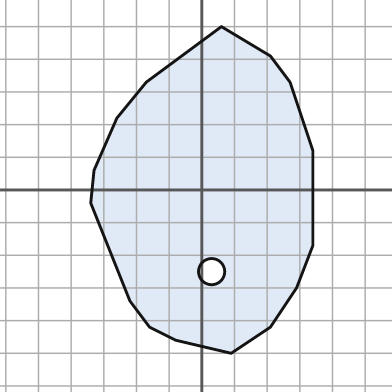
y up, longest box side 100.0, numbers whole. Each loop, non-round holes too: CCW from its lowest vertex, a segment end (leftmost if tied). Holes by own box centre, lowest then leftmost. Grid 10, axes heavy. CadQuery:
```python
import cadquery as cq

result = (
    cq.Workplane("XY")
    .moveTo(9.0, -50.0)
    .lineTo(21.0, -42.0)
    .lineTo(29.0, -30.0)
    .lineTo(34.0, -17.0)
    .lineTo(34.0, 12.0)
    .lineTo(27.0, 33.0)
    .lineTo(21.0, 41.0)
    .lineTo(6.0, 50.0)
    .lineTo(-17.0, 33.0)
    .lineTo(-26.0, 22.0)
    .lineTo(-33.0, 6.0)
    .lineTo(-34.0, -4.0)
    .lineTo(-22.0, -34.0)
    .lineTo(-16.0, -42.0)
    .lineTo(-8.0, -46.0)
    .close()
    .moveTo(3.0, -25.0)
    .circle(4.0)
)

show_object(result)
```